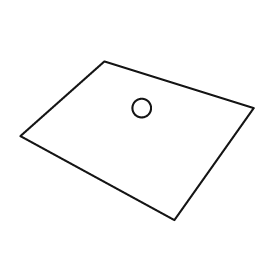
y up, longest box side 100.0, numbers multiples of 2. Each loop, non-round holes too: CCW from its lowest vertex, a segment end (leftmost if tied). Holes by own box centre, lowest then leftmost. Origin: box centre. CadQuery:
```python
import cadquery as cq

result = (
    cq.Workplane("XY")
    .moveTo(16.0, -34.0)
    .lineTo(50.0, 14.0)
    .lineTo(-14.0, 34.0)
    .lineTo(-50.0, 2.0)
    .close()
    .moveTo(2.0, 14.0)
    .circle(4.0)
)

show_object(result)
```